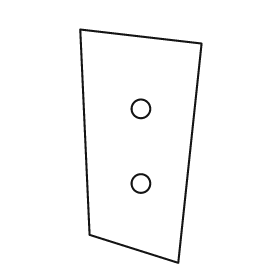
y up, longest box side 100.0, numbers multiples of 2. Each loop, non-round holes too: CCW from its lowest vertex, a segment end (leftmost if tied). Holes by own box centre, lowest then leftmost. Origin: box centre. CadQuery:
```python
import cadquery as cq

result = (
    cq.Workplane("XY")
    .moveTo(16.0, -50.0)
    .lineTo(26.0, 44.0)
    .lineTo(-26.0, 50.0)
    .lineTo(-22.0, -38.0)
    .close()
    .moveTo(0.0, -16.0)
    .circle(4.0)
    .moveTo(0.0, 16.0)
    .circle(4.0)
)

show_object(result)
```